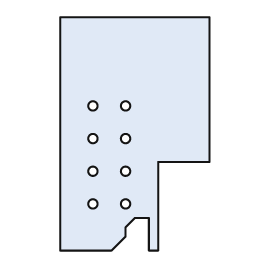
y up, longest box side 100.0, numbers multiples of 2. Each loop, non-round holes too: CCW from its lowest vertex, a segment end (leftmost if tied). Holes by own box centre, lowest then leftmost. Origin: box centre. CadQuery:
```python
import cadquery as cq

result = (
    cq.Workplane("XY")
    .moveTo(-32.0, -50.0)
    .lineTo(-10.0, -50.0)
    .lineTo(-4.0, -44.0)
    .lineTo(-4.0, -40.0)
    .lineTo(0.0, -36.0)
    .lineTo(6.0, -36.0)
    .lineTo(6.0, -50.0)
    .lineTo(10.0, -50.0)
    .lineTo(10.0, -12.0)
    .lineTo(32.0, -12.0)
    .lineTo(32.0, 50.0)
    .lineTo(-32.0, 50.0)
    .close()
    .moveTo(-18.0, -30.0)
    .circle(2.0)
    .moveTo(-4.0, -30.0)
    .circle(2.0)
    .moveTo(-18.0, -16.0)
    .circle(2.0)
    .moveTo(-4.0, -16.0)
    .circle(2.0)
    .moveTo(-18.0, -2.0)
    .circle(2.0)
    .moveTo(-4.0, -2.0)
    .circle(2.0)
    .moveTo(-18.0, 12.0)
    .circle(2.0)
    .moveTo(-4.0, 12.0)
    .circle(2.0)
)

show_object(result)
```